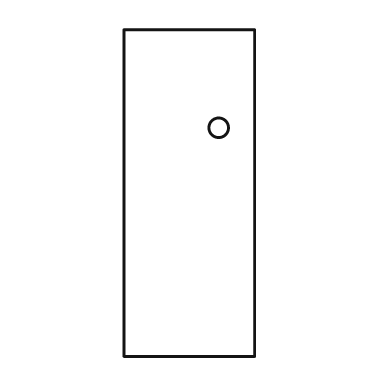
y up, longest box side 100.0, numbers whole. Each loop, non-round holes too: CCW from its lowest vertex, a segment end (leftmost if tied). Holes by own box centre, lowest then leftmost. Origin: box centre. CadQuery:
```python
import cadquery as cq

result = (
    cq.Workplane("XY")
    .moveTo(-20.0, -50.0)
    .lineTo(20.0, -50.0)
    .lineTo(20.0, 50.0)
    .lineTo(-20.0, 50.0)
    .close()
    .moveTo(9.0, 20.0)
    .circle(3.0)
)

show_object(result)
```